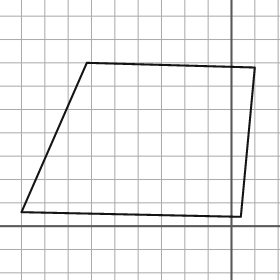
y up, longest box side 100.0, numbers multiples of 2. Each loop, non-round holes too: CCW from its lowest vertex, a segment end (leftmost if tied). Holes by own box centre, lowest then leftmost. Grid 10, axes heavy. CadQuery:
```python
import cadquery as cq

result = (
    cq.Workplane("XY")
    .moveTo(4.0, 4.0)
    .lineTo(10.0, 68.0)
    .lineTo(-62.0, 70.0)
    .lineTo(-90.0, 6.0)
    .close()
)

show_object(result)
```